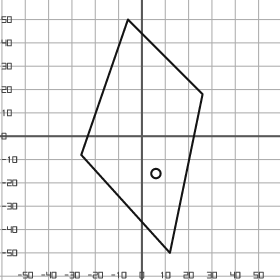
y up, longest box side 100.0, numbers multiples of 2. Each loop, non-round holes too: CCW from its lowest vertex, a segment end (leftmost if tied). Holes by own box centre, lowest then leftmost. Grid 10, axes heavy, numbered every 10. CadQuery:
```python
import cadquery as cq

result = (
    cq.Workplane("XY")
    .moveTo(12.0, -50.0)
    .lineTo(26.0, 18.0)
    .lineTo(-6.0, 50.0)
    .lineTo(-26.0, -8.0)
    .close()
    .moveTo(6.0, -16.0)
    .circle(2.0)
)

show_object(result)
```